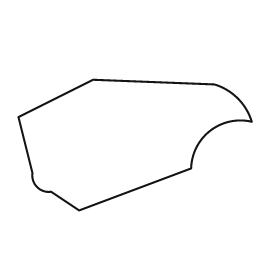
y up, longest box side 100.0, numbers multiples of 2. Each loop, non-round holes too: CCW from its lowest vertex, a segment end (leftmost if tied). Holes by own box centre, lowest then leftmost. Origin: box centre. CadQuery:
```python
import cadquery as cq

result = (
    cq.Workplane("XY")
    .moveTo(-24.0, -28.0)
    .lineTo(24.0, -10.0)
    .threePointArc((32.0, 6.0), (50.0, 10.0))
    .threePointArc((44.0, 20.0), (34.0, 26.0))
    .lineTo(-18.0, 28.0)
    .lineTo(-50.0, 12.0)
    .lineTo(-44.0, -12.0)
    .threePointArc((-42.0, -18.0), (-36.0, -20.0))
    .close()
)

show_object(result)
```